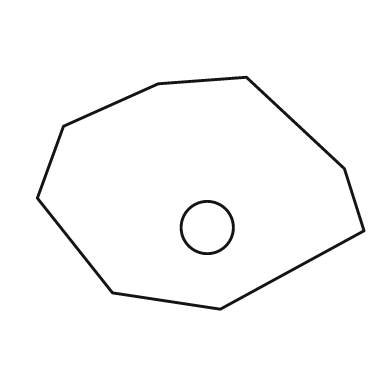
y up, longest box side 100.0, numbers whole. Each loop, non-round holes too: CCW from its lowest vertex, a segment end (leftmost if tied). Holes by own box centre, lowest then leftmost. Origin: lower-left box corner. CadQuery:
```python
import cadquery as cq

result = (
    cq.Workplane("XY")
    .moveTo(56.0, 0.0)
    .lineTo(100.0, 24.0)
    .lineTo(94.0, 43.0)
    .lineTo(64.0, 71.0)
    .lineTo(37.0, 69.0)
    .lineTo(8.0, 56.0)
    .lineTo(0.0, 34.0)
    .lineTo(23.0, 5.0)
    .close()
    .moveTo(52.0, 25.0)
    .circle(8.0)
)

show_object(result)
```